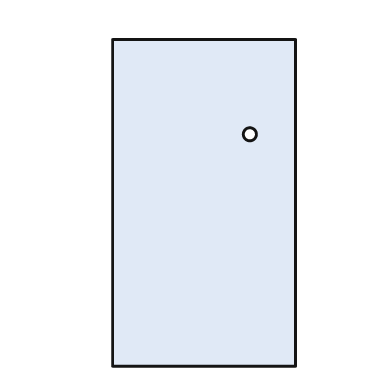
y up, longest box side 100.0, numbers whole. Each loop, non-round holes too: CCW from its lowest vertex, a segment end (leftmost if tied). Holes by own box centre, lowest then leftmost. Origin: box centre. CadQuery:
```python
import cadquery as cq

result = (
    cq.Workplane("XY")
    .moveTo(-28.0, -50.0)
    .lineTo(28.0, -50.0)
    .lineTo(28.0, 50.0)
    .lineTo(-28.0, 50.0)
    .close()
    .moveTo(14.0, 21.0)
    .circle(2.0)
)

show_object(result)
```